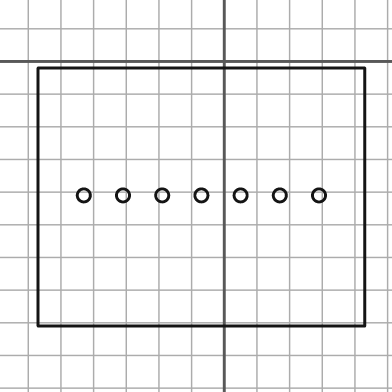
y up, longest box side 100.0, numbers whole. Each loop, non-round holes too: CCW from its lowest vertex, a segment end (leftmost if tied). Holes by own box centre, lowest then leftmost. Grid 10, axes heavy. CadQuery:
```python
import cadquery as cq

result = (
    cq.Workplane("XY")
    .moveTo(-57.0, -81.0)
    .lineTo(43.0, -81.0)
    .lineTo(43.0, -2.0)
    .lineTo(-57.0, -2.0)
    .close()
    .moveTo(-43.0, -41.0)
    .circle(2.0)
    .moveTo(-31.0, -41.0)
    .circle(2.0)
    .moveTo(-19.0, -41.0)
    .circle(2.0)
    .moveTo(-7.0, -41.0)
    .circle(2.0)
    .moveTo(5.0, -41.0)
    .circle(2.0)
    .moveTo(17.0, -41.0)
    .circle(2.0)
    .moveTo(29.0, -41.0)
    .circle(2.0)
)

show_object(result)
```